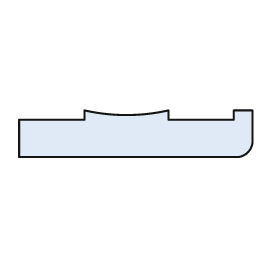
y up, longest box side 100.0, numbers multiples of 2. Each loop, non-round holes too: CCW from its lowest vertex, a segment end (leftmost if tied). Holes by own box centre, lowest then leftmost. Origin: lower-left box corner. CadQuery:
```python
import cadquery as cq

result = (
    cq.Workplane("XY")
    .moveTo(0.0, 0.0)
    .lineTo(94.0, 0.0)
    .threePointArc((98.0, 2.0), (100.0, 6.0))
    .lineTo(100.0, 20.0)
    .lineTo(92.0, 20.0)
    .lineTo(92.0, 16.0)
    .lineTo(64.0, 16.0)
    .lineTo(64.0, 20.0)
    .threePointArc((46.0, 18.0), (28.0, 20.0))
    .lineTo(28.0, 16.0)
    .lineTo(0.0, 16.0)
    .close()
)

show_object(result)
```